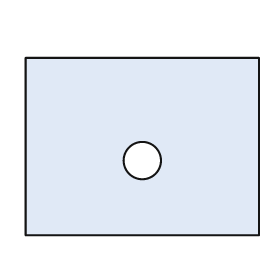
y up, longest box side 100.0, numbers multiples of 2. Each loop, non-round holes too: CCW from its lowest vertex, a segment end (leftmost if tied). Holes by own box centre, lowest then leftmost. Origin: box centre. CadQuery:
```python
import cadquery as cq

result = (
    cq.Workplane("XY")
    .moveTo(-50.0, -38.0)
    .lineTo(50.0, -38.0)
    .lineTo(50.0, 38.0)
    .lineTo(-50.0, 38.0)
    .close()
    .moveTo(0.0, -6.0)
    .circle(8.0)
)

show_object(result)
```